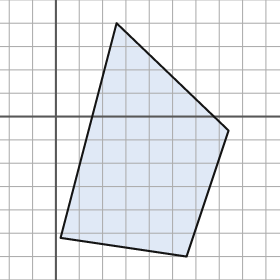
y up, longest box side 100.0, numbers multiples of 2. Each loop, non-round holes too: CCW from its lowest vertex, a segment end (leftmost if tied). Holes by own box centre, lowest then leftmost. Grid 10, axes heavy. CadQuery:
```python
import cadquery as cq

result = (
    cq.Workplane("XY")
    .moveTo(56.0, -60.0)
    .lineTo(74.0, -6.0)
    .lineTo(26.0, 40.0)
    .lineTo(2.0, -52.0)
    .close()
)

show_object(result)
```